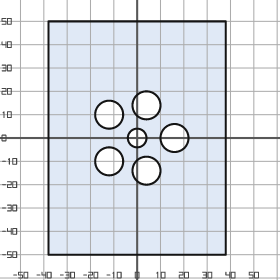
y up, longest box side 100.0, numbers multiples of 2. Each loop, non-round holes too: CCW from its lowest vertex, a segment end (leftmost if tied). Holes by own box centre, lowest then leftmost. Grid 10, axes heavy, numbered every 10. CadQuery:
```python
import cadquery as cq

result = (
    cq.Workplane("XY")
    .moveTo(-38.0, -50.0)
    .lineTo(38.0, -50.0)
    .lineTo(38.0, 50.0)
    .lineTo(-38.0, 50.0)
    .close()
    .moveTo(4.0, -14.0)
    .circle(6.0)
    .moveTo(-12.0, -10.0)
    .circle(6.0)
    .moveTo(0.0, 0.0)
    .circle(4.0)
    .moveTo(16.0, 0.0)
    .circle(6.0)
    .moveTo(-12.0, 10.0)
    .circle(6.0)
    .moveTo(4.0, 14.0)
    .circle(6.0)
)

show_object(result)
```